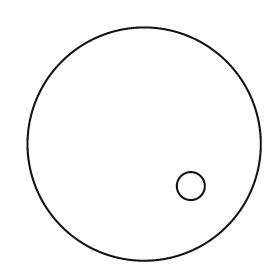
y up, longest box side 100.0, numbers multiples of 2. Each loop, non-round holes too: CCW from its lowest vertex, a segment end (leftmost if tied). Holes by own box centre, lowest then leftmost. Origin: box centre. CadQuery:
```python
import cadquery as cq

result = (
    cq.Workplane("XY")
    .moveTo(0.0, 0.0)
    .circle(50.0)
    .moveTo(20.0, -18.0)
    .circle(6.0)
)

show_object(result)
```